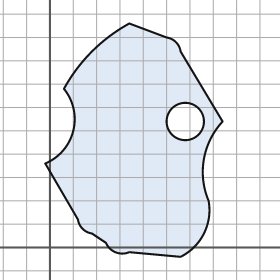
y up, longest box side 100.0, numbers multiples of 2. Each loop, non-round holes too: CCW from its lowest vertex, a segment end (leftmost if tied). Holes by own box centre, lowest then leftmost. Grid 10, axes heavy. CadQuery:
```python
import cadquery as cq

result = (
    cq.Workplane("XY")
    .moveTo(56.0, -4.0)
    .threePointArc((66.0, 6.0), (68.0, 20.0))
    .threePointArc((66.0, 38.0), (74.0, 54.0))
    .lineTo(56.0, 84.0)
    .threePointArc((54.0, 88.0), (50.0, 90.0))
    .lineTo(34.0, 96.0)
    .threePointArc((18.0, 84.0), (6.0, 68.0))
    .threePointArc((10.0, 50.0), (-2.0, 36.0))
    .lineTo(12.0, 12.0)
    .threePointArc((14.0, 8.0), (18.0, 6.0))
    .lineTo(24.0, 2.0)
    .threePointArc((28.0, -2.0), (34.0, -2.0))
    .close()
    .moveTo(58.0, 54.0)
    .circle(8.0)
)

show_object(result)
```